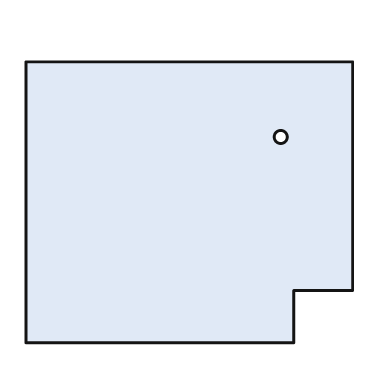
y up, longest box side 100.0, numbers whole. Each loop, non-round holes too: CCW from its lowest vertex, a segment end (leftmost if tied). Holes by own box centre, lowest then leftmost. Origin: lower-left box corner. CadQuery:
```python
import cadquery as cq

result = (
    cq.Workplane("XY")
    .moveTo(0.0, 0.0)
    .lineTo(82.0, 0.0)
    .lineTo(82.0, 16.0)
    .lineTo(100.0, 16.0)
    .lineTo(100.0, 86.0)
    .lineTo(0.0, 86.0)
    .close()
    .moveTo(78.0, 63.0)
    .circle(2.0)
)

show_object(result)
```